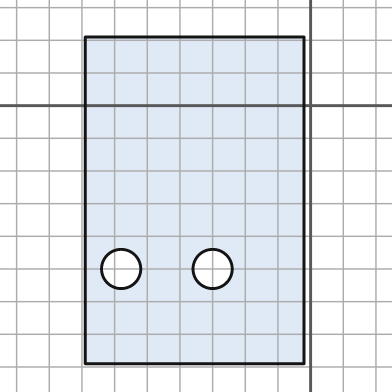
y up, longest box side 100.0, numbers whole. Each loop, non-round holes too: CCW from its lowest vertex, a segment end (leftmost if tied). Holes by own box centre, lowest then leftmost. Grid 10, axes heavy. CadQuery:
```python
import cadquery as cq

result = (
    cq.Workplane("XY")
    .moveTo(-69.0, -79.0)
    .lineTo(-2.0, -79.0)
    .lineTo(-2.0, 21.0)
    .lineTo(-69.0, 21.0)
    .close()
    .moveTo(-58.0, -50.0)
    .circle(6.0)
    .moveTo(-30.0, -50.0)
    .circle(6.0)
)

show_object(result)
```